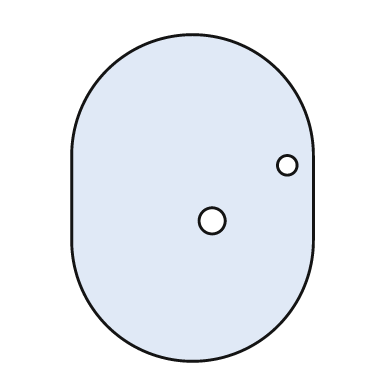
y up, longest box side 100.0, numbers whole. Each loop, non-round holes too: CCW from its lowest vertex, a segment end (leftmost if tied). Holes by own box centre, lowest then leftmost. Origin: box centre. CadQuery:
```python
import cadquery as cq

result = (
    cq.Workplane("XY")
    .moveTo(-37.0, -13.0)
    .threePointArc((0.0, -50.0), (37.0, -13.0))
    .lineTo(37.0, 13.0)
    .threePointArc((0.0, 50.0), (-37.0, 13.0))
    .close()
    .moveTo(6.0, -7.0)
    .circle(4.0)
    .moveTo(29.0, 10.0)
    .circle(3.0)
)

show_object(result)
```